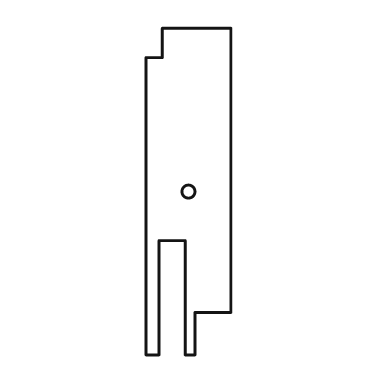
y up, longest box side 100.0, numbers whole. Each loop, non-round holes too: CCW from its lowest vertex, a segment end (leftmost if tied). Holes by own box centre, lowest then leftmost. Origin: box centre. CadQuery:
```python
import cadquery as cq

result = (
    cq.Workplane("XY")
    .moveTo(-13.0, -50.0)
    .lineTo(-9.0, -50.0)
    .lineTo(-9.0, -15.0)
    .lineTo(-1.0, -15.0)
    .lineTo(-1.0, -50.0)
    .lineTo(2.0, -50.0)
    .lineTo(2.0, -37.0)
    .lineTo(13.0, -37.0)
    .lineTo(13.0, 50.0)
    .lineTo(-8.0, 50.0)
    .lineTo(-8.0, 41.0)
    .lineTo(-13.0, 41.0)
    .close()
    .moveTo(0.0, 0.0)
    .circle(2.0)
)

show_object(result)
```